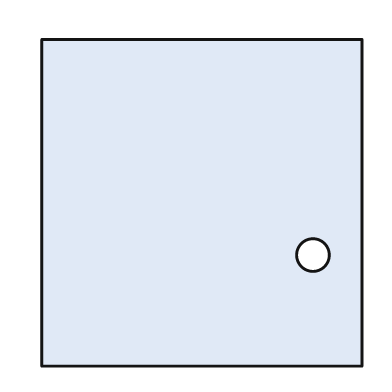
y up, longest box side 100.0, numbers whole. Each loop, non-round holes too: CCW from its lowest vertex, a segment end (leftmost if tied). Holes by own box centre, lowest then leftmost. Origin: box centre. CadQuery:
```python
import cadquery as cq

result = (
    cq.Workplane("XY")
    .moveTo(-49.0, -50.0)
    .lineTo(49.0, -50.0)
    .lineTo(49.0, 50.0)
    .lineTo(-49.0, 50.0)
    .close()
    .moveTo(34.0, -16.0)
    .circle(5.0)
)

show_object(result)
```